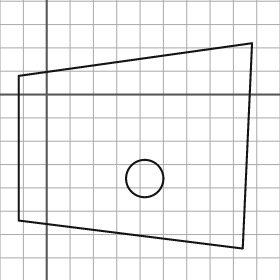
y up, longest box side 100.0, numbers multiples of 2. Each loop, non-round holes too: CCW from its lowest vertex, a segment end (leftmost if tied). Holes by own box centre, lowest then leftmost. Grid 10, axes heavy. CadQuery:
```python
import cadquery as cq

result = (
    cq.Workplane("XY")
    .moveTo(84.0, -66.0)
    .lineTo(88.0, 22.0)
    .lineTo(-12.0, 8.0)
    .lineTo(-12.0, -54.0)
    .close()
    .moveTo(42.0, -36.0)
    .circle(8.0)
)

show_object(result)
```